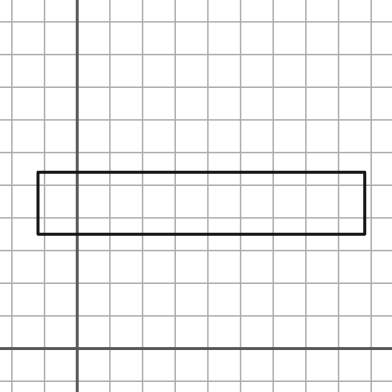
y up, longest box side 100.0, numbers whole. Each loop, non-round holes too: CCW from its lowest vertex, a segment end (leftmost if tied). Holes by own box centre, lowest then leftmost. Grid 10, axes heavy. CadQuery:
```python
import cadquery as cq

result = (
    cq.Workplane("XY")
    .moveTo(-12.0, 35.0)
    .lineTo(88.0, 35.0)
    .lineTo(88.0, 54.0)
    .lineTo(-12.0, 54.0)
    .close()
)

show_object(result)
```